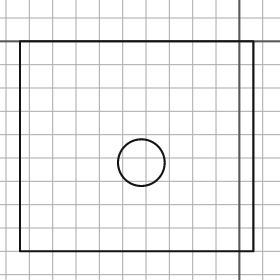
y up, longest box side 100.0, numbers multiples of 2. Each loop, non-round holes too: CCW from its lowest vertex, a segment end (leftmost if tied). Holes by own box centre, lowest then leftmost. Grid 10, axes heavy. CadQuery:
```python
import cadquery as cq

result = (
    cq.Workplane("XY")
    .moveTo(-94.0, -90.0)
    .lineTo(6.0, -90.0)
    .lineTo(6.0, 0.0)
    .lineTo(-94.0, 0.0)
    .close()
    .moveTo(-42.0, -52.0)
    .circle(10.0)
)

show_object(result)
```